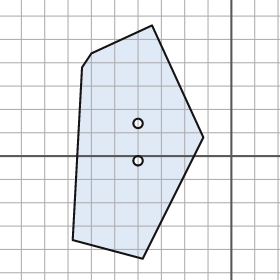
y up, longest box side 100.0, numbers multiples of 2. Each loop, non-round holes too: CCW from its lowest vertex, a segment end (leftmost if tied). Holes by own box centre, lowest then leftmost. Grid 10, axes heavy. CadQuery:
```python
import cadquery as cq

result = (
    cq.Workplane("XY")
    .moveTo(-38.0, -44.0)
    .lineTo(-12.0, 8.0)
    .lineTo(-34.0, 56.0)
    .lineTo(-60.0, 44.0)
    .lineTo(-64.0, 38.0)
    .lineTo(-68.0, -36.0)
    .close()
    .moveTo(-40.0, -2.0)
    .circle(2.0)
    .moveTo(-40.0, 14.0)
    .circle(2.0)
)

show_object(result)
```